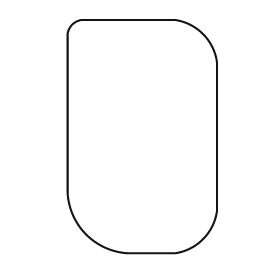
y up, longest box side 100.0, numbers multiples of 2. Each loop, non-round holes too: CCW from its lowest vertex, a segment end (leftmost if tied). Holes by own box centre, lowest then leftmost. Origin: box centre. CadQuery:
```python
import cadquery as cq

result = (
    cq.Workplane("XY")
    .moveTo(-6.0, -50.0)
    .lineTo(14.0, -50.0)
    .threePointArc((26.0, -44.0), (32.0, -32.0))
    .lineTo(32.0, 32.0)
    .threePointArc((26.0, 44.0), (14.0, 50.0))
    .lineTo(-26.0, 50.0)
    .threePointArc((-30.0, 48.0), (-32.0, 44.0))
    .lineTo(-32.0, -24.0)
    .threePointArc((-24.0, -42.0), (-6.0, -50.0))
    .close()
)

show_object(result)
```